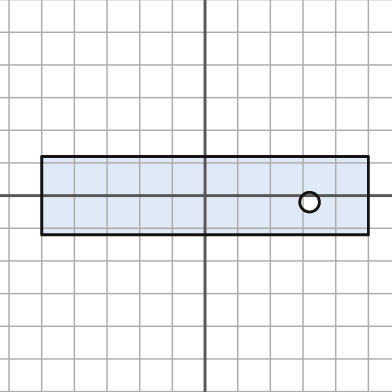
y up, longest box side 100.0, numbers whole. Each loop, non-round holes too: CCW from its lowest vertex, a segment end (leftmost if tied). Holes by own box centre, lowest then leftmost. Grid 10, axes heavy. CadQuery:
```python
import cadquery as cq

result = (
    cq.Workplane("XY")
    .moveTo(-50.0, -12.0)
    .lineTo(50.0, -12.0)
    .lineTo(50.0, 12.0)
    .lineTo(-50.0, 12.0)
    .close()
    .moveTo(32.0, -2.0)
    .circle(3.0)
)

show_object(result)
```